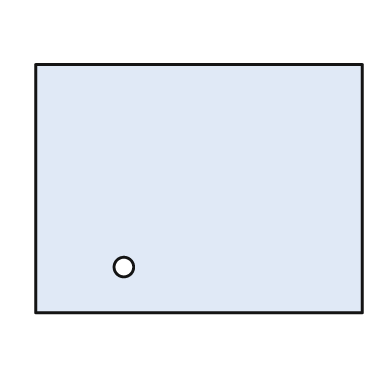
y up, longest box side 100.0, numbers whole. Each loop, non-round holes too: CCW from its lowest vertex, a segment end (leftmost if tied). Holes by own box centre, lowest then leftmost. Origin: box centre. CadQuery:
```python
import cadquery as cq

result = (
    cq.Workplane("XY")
    .moveTo(-50.0, -38.0)
    .lineTo(50.0, -38.0)
    .lineTo(50.0, 38.0)
    .lineTo(-50.0, 38.0)
    .close()
    .moveTo(-23.0, -24.0)
    .circle(3.0)
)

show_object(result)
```